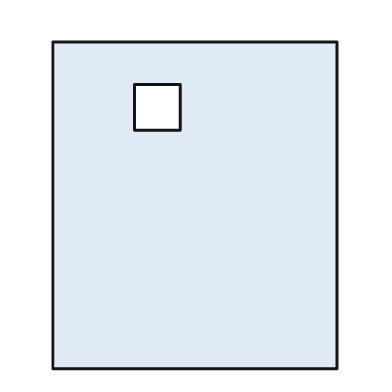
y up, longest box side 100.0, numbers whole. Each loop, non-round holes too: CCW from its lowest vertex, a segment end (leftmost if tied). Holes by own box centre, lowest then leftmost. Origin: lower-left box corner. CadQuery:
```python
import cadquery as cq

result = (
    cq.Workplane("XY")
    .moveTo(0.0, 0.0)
    .lineTo(87.0, 0.0)
    .lineTo(87.0, 100.0)
    .lineTo(0.0, 100.0)
    .close()
    .moveTo(25.0, 73.0)
    .lineTo(39.0, 73.0)
    .lineTo(39.0, 87.0)
    .lineTo(25.0, 87.0)
    .close()
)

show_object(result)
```